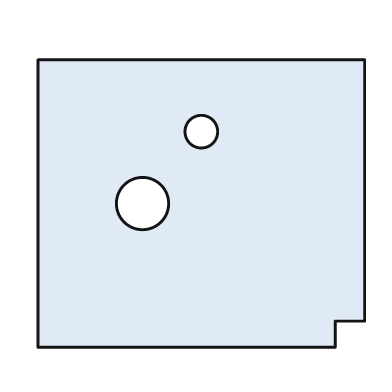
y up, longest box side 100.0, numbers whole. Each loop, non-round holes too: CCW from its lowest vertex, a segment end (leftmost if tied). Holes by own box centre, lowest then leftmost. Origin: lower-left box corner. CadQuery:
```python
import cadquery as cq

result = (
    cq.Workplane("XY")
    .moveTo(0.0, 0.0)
    .lineTo(91.0, 0.0)
    .lineTo(91.0, 8.0)
    .lineTo(100.0, 8.0)
    .lineTo(100.0, 88.0)
    .lineTo(0.0, 88.0)
    .close()
    .moveTo(32.0, 44.0)
    .circle(8.0)
    .moveTo(50.0, 66.0)
    .circle(5.0)
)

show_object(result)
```